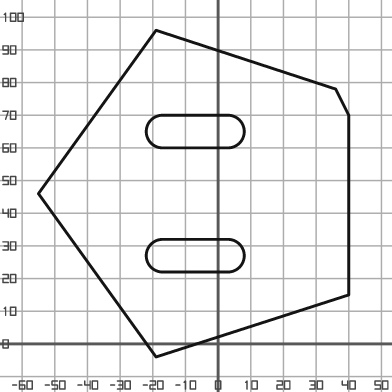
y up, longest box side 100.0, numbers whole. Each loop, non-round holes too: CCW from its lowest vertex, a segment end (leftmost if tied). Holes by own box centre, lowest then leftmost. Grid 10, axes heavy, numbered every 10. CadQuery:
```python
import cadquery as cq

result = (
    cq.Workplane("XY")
    .moveTo(-19.0, -4.0)
    .lineTo(40.0, 15.0)
    .lineTo(40.0, 70.0)
    .lineTo(36.0, 78.0)
    .lineTo(-19.0, 96.0)
    .lineTo(-55.0, 46.0)
    .close()
    .moveTo(-17.0, 22.0)
    .lineTo(3.0, 22.0)
    .threePointArc((8.0, 27.0), (3.0, 32.0))
    .lineTo(-17.0, 32.0)
    .threePointArc((-22.0, 27.0), (-17.0, 22.0))
    .close()
    .moveTo(-17.0, 60.0)
    .lineTo(3.0, 60.0)
    .threePointArc((8.0, 65.0), (3.0, 70.0))
    .lineTo(-17.0, 70.0)
    .threePointArc((-22.0, 65.0), (-17.0, 60.0))
    .close()
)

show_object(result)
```